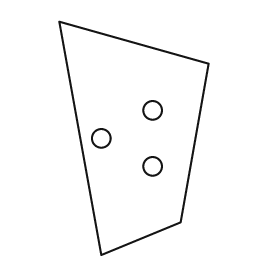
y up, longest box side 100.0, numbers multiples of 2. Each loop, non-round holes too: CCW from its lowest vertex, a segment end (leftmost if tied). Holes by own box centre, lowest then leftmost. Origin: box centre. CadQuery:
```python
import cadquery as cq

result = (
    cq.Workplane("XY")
    .moveTo(-14.0, -50.0)
    .lineTo(20.0, -36.0)
    .lineTo(32.0, 32.0)
    .lineTo(-32.0, 50.0)
    .close()
    .moveTo(8.0, -12.0)
    .circle(4.0)
    .moveTo(-14.0, 0.0)
    .circle(4.0)
    .moveTo(8.0, 12.0)
    .circle(4.0)
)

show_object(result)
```